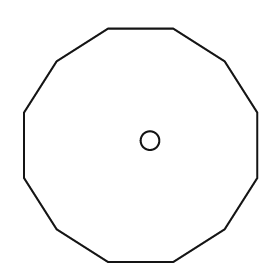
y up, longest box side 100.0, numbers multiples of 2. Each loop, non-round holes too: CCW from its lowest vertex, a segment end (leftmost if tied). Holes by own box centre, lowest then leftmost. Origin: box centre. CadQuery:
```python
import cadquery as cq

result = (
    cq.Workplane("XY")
    .moveTo(-14.0, -50.0)
    .lineTo(14.0, -50.0)
    .lineTo(36.0, -36.0)
    .lineTo(50.0, -14.0)
    .lineTo(50.0, 14.0)
    .lineTo(36.0, 36.0)
    .lineTo(14.0, 50.0)
    .lineTo(-14.0, 50.0)
    .lineTo(-36.0, 36.0)
    .lineTo(-50.0, 14.0)
    .lineTo(-50.0, -14.0)
    .lineTo(-36.0, -36.0)
    .close()
    .moveTo(4.0, 2.0)
    .circle(4.0)
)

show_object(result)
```